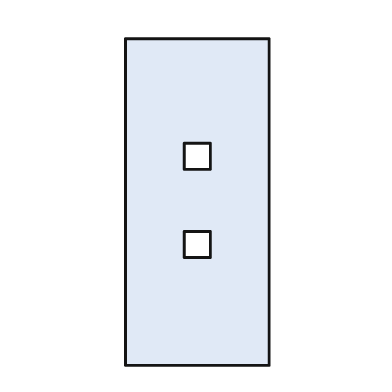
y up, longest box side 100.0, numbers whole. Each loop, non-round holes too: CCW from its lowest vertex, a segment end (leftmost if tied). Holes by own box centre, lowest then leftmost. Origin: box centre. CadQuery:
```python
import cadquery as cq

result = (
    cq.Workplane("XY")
    .moveTo(-22.0, -50.0)
    .lineTo(22.0, -50.0)
    .lineTo(22.0, 50.0)
    .lineTo(-22.0, 50.0)
    .close()
    .moveTo(-4.0, -17.0)
    .lineTo(4.0, -17.0)
    .lineTo(4.0, -9.0)
    .lineTo(-4.0, -9.0)
    .close()
    .moveTo(-4.0, 10.0)
    .lineTo(4.0, 10.0)
    .lineTo(4.0, 18.0)
    .lineTo(-4.0, 18.0)
    .close()
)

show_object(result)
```